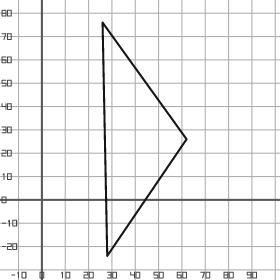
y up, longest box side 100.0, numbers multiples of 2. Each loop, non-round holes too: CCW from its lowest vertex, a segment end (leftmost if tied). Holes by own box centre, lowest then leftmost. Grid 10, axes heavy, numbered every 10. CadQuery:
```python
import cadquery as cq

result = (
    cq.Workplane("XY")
    .moveTo(28.0, -24.0)
    .lineTo(62.0, 26.0)
    .lineTo(26.0, 76.0)
    .close()
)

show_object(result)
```